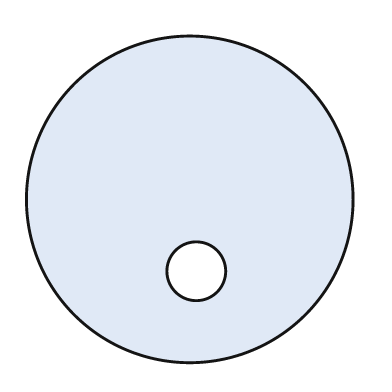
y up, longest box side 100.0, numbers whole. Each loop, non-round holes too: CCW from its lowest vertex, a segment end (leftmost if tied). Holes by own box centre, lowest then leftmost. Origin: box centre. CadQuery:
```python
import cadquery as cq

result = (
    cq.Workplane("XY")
    .moveTo(0.0, 0.0)
    .circle(50.0)
    .moveTo(2.0, -22.0)
    .circle(9.0)
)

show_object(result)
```